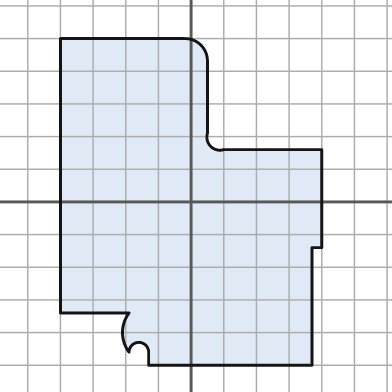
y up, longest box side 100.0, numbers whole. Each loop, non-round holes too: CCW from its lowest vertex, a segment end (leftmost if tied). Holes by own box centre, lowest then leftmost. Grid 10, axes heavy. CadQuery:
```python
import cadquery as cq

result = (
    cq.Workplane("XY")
    .moveTo(-13.0, -50.0)
    .lineTo(37.0, -50.0)
    .lineTo(37.0, -14.0)
    .lineTo(40.0, -14.0)
    .lineTo(40.0, 16.0)
    .lineTo(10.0, 16.0)
    .threePointArc((6.0, 17.0), (5.0, 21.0))
    .lineTo(5.0, 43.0)
    .threePointArc((3.0, 48.0), (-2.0, 50.0))
    .lineTo(-40.0, 50.0)
    .lineTo(-40.0, -34.0)
    .lineTo(-19.0, -34.0)
    .threePointArc((-21.0, -40.0), (-19.0, -46.0))
    .threePointArc((-16.0, -43.0), (-13.0, -46.0))
    .close()
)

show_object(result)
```